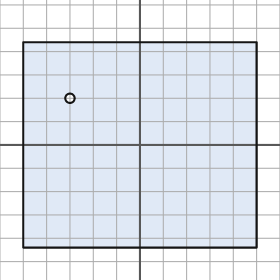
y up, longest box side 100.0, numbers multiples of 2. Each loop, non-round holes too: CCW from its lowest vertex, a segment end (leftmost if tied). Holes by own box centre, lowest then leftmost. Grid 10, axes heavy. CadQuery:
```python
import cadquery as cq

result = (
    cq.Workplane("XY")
    .moveTo(-50.0, -44.0)
    .lineTo(50.0, -44.0)
    .lineTo(50.0, 44.0)
    .lineTo(-50.0, 44.0)
    .close()
    .moveTo(-30.0, 20.0)
    .circle(2.0)
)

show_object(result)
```